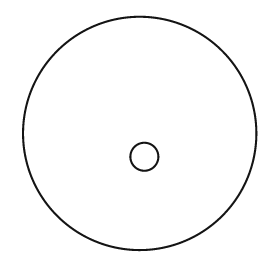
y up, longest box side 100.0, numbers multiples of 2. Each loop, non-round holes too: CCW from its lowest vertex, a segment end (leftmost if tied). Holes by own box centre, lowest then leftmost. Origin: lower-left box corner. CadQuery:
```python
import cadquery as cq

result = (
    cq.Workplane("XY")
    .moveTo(50.0, 50.0)
    .circle(50.0)
    .moveTo(52.0, 40.0)
    .circle(6.0)
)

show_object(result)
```